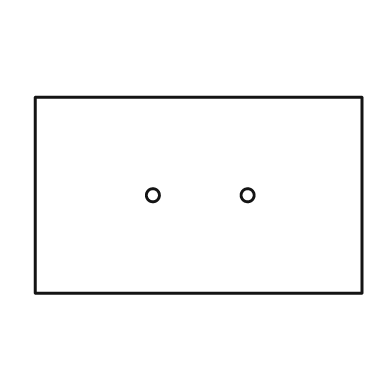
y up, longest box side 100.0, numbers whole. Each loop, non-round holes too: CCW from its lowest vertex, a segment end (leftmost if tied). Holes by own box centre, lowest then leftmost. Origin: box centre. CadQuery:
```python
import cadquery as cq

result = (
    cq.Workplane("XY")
    .moveTo(-50.0, -30.0)
    .lineTo(50.0, -30.0)
    .lineTo(50.0, 30.0)
    .lineTo(-50.0, 30.0)
    .close()
    .moveTo(-14.0, 0.0)
    .circle(2.0)
    .moveTo(15.0, 0.0)
    .circle(2.0)
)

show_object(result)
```